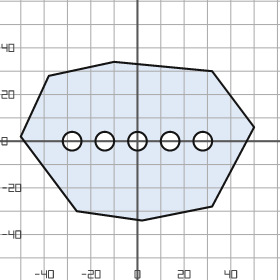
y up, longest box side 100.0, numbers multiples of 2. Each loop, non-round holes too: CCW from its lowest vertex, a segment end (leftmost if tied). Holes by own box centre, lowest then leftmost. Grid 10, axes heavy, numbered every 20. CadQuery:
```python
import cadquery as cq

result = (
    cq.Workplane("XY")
    .moveTo(2.0, -34.0)
    .lineTo(32.0, -28.0)
    .lineTo(50.0, 6.0)
    .lineTo(32.0, 30.0)
    .lineTo(-10.0, 34.0)
    .lineTo(-38.0, 28.0)
    .lineTo(-50.0, 2.0)
    .lineTo(-26.0, -30.0)
    .close()
    .moveTo(-28.0, 0.0)
    .circle(4.0)
    .moveTo(-14.0, 0.0)
    .circle(4.0)
    .moveTo(0.0, 0.0)
    .circle(4.0)
    .moveTo(14.0, 0.0)
    .circle(4.0)
    .moveTo(28.0, 0.0)
    .circle(4.0)
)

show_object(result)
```